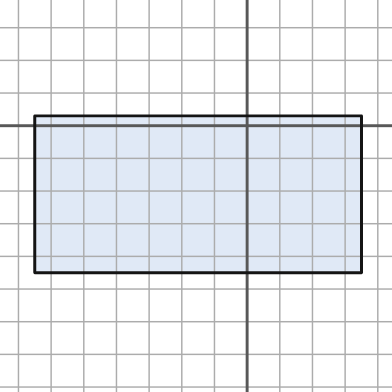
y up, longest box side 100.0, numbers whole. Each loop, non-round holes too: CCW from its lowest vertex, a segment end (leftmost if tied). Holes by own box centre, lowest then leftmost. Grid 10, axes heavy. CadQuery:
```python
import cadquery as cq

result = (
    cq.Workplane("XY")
    .moveTo(-65.0, -45.0)
    .lineTo(35.0, -45.0)
    .lineTo(35.0, 3.0)
    .lineTo(-65.0, 3.0)
    .close()
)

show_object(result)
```